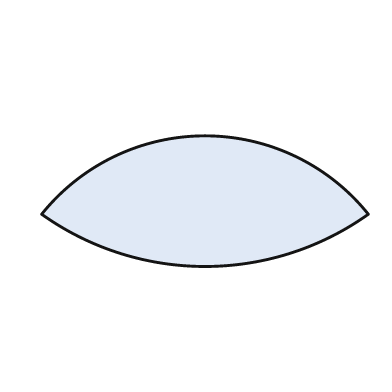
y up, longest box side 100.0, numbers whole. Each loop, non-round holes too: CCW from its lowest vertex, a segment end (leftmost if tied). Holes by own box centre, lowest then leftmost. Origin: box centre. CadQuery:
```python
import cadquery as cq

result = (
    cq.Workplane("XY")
    .moveTo(-50.0, -4.0)
    .threePointArc((0.0, -20.0), (50.0, -4.0))
    .threePointArc((0.0, 20.0), (-50.0, -4.0))
    .close()
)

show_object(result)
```